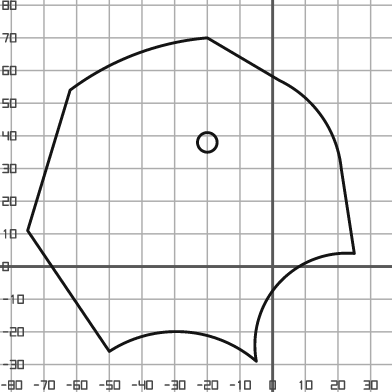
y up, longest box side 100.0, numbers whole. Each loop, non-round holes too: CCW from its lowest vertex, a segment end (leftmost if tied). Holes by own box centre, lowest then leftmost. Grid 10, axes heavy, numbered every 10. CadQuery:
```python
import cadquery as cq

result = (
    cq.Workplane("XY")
    .moveTo(-5.0, -29.0)
    .threePointArc((2.0, -5.0), (25.0, 4.0))
    .lineTo(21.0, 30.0)
    .threePointArc((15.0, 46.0), (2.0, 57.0))
    .lineTo(-20.0, 70.0)
    .threePointArc((-42.0, 65.0), (-62.0, 54.0))
    .lineTo(-75.0, 11.0)
    .lineTo(-50.0, -26.0)
    .threePointArc((-27.0, -20.0), (-5.0, -29.0))
    .close()
    .moveTo(-20.0, 38.0)
    .circle(3.0)
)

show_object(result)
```